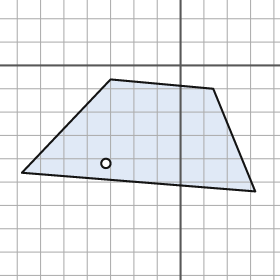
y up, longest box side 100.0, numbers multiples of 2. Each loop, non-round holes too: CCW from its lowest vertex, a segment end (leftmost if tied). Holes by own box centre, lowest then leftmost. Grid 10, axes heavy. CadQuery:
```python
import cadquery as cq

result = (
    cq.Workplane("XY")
    .moveTo(32.0, -54.0)
    .lineTo(14.0, -10.0)
    .lineTo(-30.0, -6.0)
    .lineTo(-68.0, -46.0)
    .close()
    .moveTo(-32.0, -42.0)
    .circle(2.0)
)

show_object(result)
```